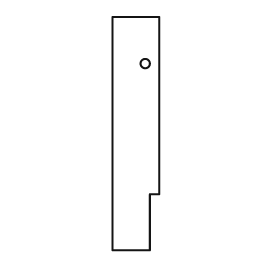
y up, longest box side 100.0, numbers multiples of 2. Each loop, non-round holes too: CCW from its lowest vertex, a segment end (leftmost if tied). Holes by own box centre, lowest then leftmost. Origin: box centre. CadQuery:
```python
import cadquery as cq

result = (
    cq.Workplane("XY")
    .moveTo(-10.0, -50.0)
    .lineTo(6.0, -50.0)
    .lineTo(6.0, -26.0)
    .lineTo(10.0, -26.0)
    .lineTo(10.0, 50.0)
    .lineTo(-10.0, 50.0)
    .close()
    .moveTo(4.0, 30.0)
    .circle(2.0)
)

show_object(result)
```